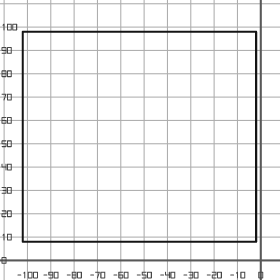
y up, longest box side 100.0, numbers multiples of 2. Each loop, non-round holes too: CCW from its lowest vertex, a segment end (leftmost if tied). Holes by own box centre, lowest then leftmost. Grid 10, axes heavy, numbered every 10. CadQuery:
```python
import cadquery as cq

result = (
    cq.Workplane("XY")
    .moveTo(-102.0, 8.0)
    .lineTo(-2.0, 8.0)
    .lineTo(-2.0, 98.0)
    .lineTo(-102.0, 98.0)
    .close()
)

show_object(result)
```